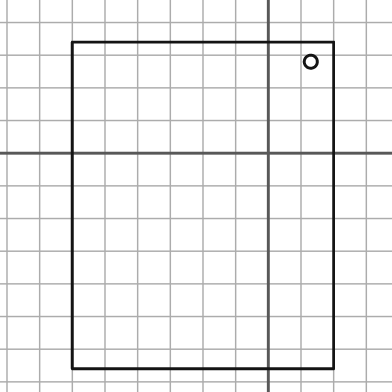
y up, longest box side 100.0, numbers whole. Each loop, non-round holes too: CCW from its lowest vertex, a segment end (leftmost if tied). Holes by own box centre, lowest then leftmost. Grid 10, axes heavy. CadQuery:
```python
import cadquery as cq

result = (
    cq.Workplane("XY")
    .moveTo(-60.0, -66.0)
    .lineTo(20.0, -66.0)
    .lineTo(20.0, 34.0)
    .lineTo(-60.0, 34.0)
    .close()
    .moveTo(13.0, 28.0)
    .circle(2.0)
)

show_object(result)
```